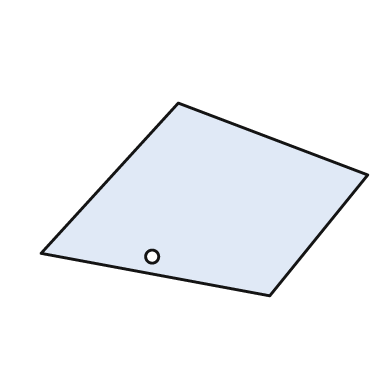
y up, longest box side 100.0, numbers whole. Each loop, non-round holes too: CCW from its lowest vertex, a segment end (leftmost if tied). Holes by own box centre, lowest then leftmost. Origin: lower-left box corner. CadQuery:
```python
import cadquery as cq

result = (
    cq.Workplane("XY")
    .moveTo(70.0, 0.0)
    .lineTo(100.0, 37.0)
    .lineTo(42.0, 59.0)
    .lineTo(0.0, 13.0)
    .close()
    .moveTo(34.0, 12.0)
    .circle(2.0)
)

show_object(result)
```